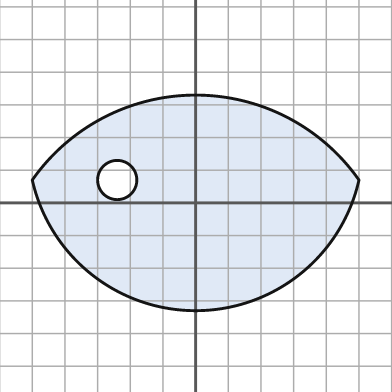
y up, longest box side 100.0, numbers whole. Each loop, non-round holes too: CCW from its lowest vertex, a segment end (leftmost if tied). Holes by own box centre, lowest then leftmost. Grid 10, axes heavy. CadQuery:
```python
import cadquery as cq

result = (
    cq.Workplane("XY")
    .moveTo(-50.0, 7.0)
    .threePointArc((0.0, -33.0), (50.0, 7.0))
    .threePointArc((0.0, 33.0), (-50.0, 7.0))
    .close()
    .moveTo(-24.0, 7.0)
    .circle(6.0)
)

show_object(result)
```